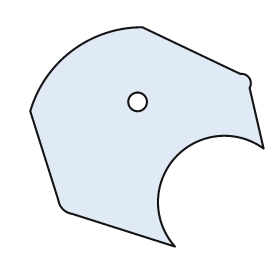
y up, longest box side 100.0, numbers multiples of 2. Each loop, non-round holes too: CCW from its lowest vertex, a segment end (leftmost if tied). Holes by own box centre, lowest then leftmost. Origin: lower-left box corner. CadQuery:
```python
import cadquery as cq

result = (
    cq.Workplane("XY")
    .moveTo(62.0, 0.0)
    .threePointArc((62.0, 38.0), (100.0, 42.0))
    .lineTo(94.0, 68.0)
    .threePointArc((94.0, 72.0), (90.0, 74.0))
    .lineTo(48.0, 94.0)
    .threePointArc((18.0, 84.0), (0.0, 58.0))
    .lineTo(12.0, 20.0)
    .threePointArc((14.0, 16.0), (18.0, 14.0))
    .close()
    .moveTo(46.0, 62.0)
    .circle(4.0)
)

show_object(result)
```